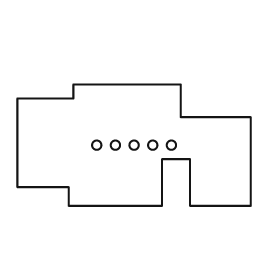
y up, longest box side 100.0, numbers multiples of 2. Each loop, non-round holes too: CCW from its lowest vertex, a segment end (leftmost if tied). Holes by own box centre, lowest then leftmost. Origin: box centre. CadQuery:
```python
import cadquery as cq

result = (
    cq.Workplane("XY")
    .moveTo(-28.0, -26.0)
    .lineTo(12.0, -26.0)
    .lineTo(12.0, -6.0)
    .lineTo(24.0, -6.0)
    .lineTo(24.0, -26.0)
    .lineTo(50.0, -26.0)
    .lineTo(50.0, 12.0)
    .lineTo(20.0, 12.0)
    .lineTo(20.0, 26.0)
    .lineTo(-26.0, 26.0)
    .lineTo(-26.0, 20.0)
    .lineTo(-50.0, 20.0)
    .lineTo(-50.0, -18.0)
    .lineTo(-28.0, -18.0)
    .close()
    .moveTo(-16.0, 0.0)
    .circle(2.0)
    .moveTo(-8.0, 0.0)
    .circle(2.0)
    .moveTo(0.0, 0.0)
    .circle(2.0)
    .moveTo(8.0, 0.0)
    .circle(2.0)
    .moveTo(16.0, 0.0)
    .circle(2.0)
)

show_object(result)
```